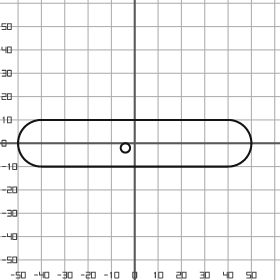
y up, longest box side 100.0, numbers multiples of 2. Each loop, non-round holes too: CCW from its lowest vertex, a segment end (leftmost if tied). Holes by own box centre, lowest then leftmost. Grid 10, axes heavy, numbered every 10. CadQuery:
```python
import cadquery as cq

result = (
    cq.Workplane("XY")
    .moveTo(-40.0, -10.0)
    .lineTo(40.0, -10.0)
    .threePointArc((50.0, 0.0), (40.0, 10.0))
    .lineTo(-40.0, 10.0)
    .threePointArc((-50.0, 0.0), (-40.0, -10.0))
    .close()
    .moveTo(-4.0, -2.0)
    .circle(2.0)
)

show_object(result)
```